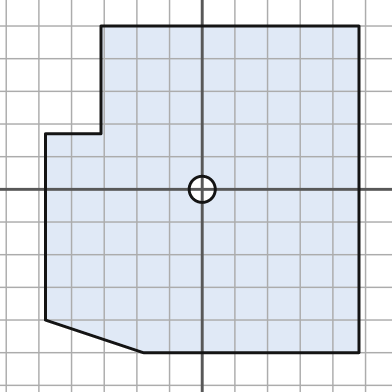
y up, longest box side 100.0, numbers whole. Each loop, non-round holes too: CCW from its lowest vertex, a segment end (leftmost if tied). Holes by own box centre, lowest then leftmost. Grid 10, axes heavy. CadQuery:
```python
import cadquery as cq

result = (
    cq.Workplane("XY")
    .moveTo(-18.0, -50.0)
    .lineTo(48.0, -50.0)
    .lineTo(48.0, 50.0)
    .lineTo(-31.0, 50.0)
    .lineTo(-31.0, 17.0)
    .lineTo(-48.0, 17.0)
    .lineTo(-48.0, -40.0)
    .close()
    .moveTo(0.0, 0.0)
    .circle(4.0)
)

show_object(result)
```